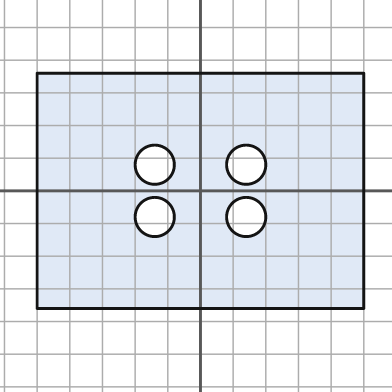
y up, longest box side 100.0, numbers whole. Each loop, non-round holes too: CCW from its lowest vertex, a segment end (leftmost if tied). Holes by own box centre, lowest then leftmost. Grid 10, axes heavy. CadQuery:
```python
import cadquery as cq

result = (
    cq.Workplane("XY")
    .moveTo(-50.0, -36.0)
    .lineTo(50.0, -36.0)
    .lineTo(50.0, 36.0)
    .lineTo(-50.0, 36.0)
    .close()
    .moveTo(-14.0, -8.0)
    .circle(6.0)
    .moveTo(14.0, -8.0)
    .circle(6.0)
    .moveTo(-14.0, 8.0)
    .circle(6.0)
    .moveTo(14.0, 8.0)
    .circle(6.0)
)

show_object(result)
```